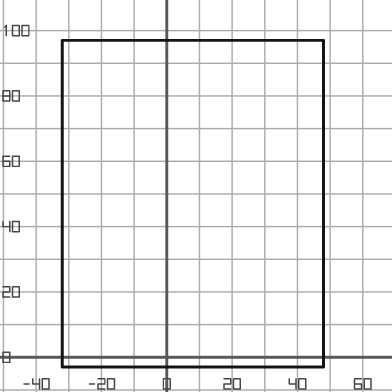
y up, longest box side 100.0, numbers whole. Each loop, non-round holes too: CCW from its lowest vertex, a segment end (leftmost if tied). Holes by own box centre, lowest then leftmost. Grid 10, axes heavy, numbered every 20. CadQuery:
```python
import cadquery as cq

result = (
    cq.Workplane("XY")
    .moveTo(-32.0, -3.0)
    .lineTo(48.0, -3.0)
    .lineTo(48.0, 97.0)
    .lineTo(-32.0, 97.0)
    .close()
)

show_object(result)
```